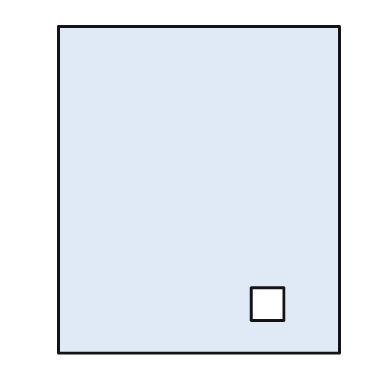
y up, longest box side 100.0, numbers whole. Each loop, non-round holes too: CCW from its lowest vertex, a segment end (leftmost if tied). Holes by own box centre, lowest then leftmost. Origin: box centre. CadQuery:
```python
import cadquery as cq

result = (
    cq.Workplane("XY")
    .moveTo(-43.0, -50.0)
    .lineTo(43.0, -50.0)
    .lineTo(43.0, 50.0)
    .lineTo(-43.0, 50.0)
    .close()
    .moveTo(16.0, -40.0)
    .lineTo(26.0, -40.0)
    .lineTo(26.0, -30.0)
    .lineTo(16.0, -30.0)
    .close()
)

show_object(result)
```